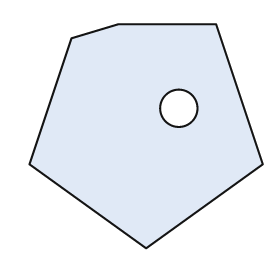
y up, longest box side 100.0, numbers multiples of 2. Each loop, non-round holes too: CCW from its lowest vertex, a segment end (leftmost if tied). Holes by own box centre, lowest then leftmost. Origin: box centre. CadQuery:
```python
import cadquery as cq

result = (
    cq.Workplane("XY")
    .moveTo(0.0, -48.0)
    .lineTo(50.0, -12.0)
    .lineTo(30.0, 48.0)
    .lineTo(-12.0, 48.0)
    .lineTo(-32.0, 42.0)
    .lineTo(-50.0, -12.0)
    .close()
    .moveTo(14.0, 12.0)
    .circle(8.0)
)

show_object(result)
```